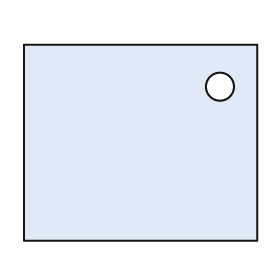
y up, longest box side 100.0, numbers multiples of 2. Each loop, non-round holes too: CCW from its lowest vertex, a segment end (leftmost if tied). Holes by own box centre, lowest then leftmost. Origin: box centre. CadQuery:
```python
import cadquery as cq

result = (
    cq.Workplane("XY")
    .moveTo(-50.0, -42.0)
    .lineTo(50.0, -42.0)
    .lineTo(50.0, 42.0)
    .lineTo(-50.0, 42.0)
    .close()
    .moveTo(34.0, 24.0)
    .circle(6.0)
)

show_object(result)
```